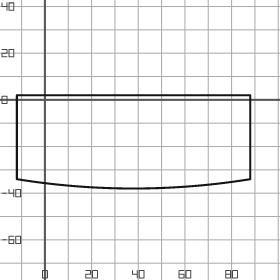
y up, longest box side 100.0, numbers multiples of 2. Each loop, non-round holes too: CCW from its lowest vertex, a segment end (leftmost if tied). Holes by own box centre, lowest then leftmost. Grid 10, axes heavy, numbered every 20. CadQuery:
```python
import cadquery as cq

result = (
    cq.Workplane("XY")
    .moveTo(-12.0, -34.0)
    .threePointArc((38.0, -38.0), (88.0, -34.0))
    .lineTo(88.0, 2.0)
    .lineTo(-12.0, 2.0)
    .close()
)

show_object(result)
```